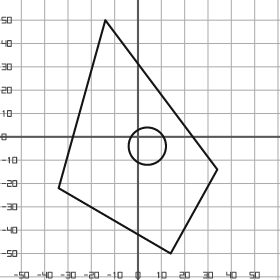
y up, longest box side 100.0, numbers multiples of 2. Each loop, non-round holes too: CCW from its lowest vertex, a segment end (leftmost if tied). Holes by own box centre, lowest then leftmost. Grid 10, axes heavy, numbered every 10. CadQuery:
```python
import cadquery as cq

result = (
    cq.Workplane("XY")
    .moveTo(14.0, -50.0)
    .lineTo(34.0, -14.0)
    .lineTo(-14.0, 50.0)
    .lineTo(-34.0, -22.0)
    .close()
    .moveTo(4.0, -4.0)
    .circle(8.0)
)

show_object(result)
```